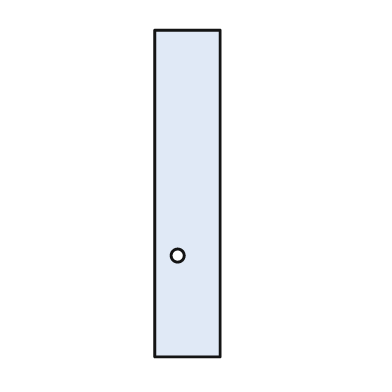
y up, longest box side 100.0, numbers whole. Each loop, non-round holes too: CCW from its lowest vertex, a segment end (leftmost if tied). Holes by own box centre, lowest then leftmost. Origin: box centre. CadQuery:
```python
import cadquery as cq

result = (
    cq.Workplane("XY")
    .moveTo(-10.0, -50.0)
    .lineTo(10.0, -50.0)
    .lineTo(10.0, 50.0)
    .lineTo(-10.0, 50.0)
    .close()
    .moveTo(-3.0, -19.0)
    .circle(2.0)
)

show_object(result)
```